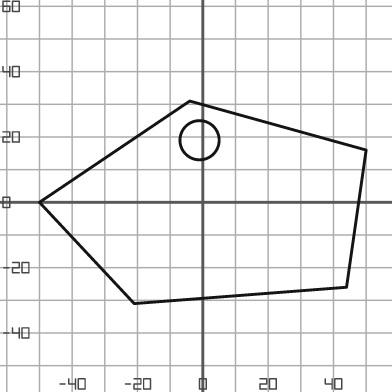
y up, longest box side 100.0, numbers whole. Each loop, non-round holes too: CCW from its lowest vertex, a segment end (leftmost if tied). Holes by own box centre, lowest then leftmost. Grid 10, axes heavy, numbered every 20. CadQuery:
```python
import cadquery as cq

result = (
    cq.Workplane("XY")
    .moveTo(-21.0, -31.0)
    .lineTo(44.0, -26.0)
    .lineTo(50.0, 16.0)
    .lineTo(-4.0, 31.0)
    .lineTo(-50.0, 0.0)
    .close()
    .moveTo(-1.0, 19.0)
    .circle(6.0)
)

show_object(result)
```